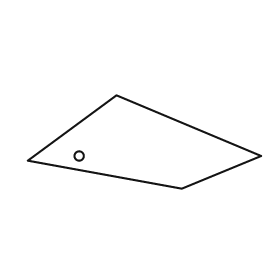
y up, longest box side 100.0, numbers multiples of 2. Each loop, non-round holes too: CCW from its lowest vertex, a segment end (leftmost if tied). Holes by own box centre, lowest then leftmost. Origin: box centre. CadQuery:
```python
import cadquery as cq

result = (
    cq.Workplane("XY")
    .moveTo(16.0, -20.0)
    .lineTo(50.0, -6.0)
    .lineTo(-12.0, 20.0)
    .lineTo(-50.0, -8.0)
    .close()
    .moveTo(-28.0, -6.0)
    .circle(2.0)
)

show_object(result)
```